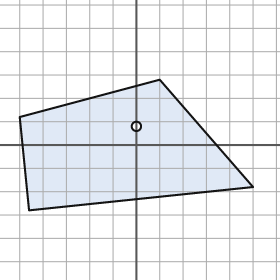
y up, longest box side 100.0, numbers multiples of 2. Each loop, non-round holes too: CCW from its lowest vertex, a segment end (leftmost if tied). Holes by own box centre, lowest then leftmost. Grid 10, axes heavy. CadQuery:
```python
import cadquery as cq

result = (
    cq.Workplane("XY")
    .moveTo(-46.0, -28.0)
    .lineTo(50.0, -18.0)
    .lineTo(10.0, 28.0)
    .lineTo(-50.0, 12.0)
    .close()
    .moveTo(0.0, 8.0)
    .circle(2.0)
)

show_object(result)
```